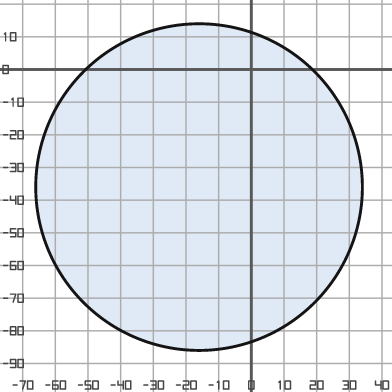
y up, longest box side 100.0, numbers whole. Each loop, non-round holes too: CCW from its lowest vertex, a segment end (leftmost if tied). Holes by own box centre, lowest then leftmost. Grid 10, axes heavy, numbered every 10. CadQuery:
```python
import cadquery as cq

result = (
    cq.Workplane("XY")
    .moveTo(-16.0, -36.0)
    .circle(50.0)
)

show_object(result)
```